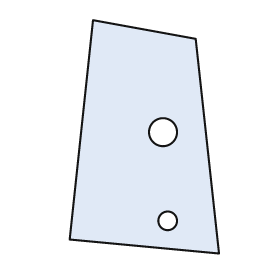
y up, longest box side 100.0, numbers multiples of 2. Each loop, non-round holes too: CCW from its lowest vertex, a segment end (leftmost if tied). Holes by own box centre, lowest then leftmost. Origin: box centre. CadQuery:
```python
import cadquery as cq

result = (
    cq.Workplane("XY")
    .moveTo(32.0, -50.0)
    .lineTo(22.0, 42.0)
    .lineTo(-22.0, 50.0)
    .lineTo(-32.0, -44.0)
    .close()
    .moveTo(10.0, -36.0)
    .circle(4.0)
    .moveTo(8.0, 2.0)
    .circle(6.0)
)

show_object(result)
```